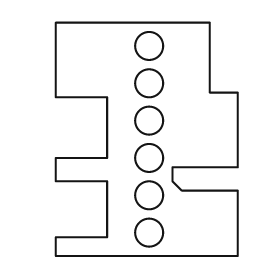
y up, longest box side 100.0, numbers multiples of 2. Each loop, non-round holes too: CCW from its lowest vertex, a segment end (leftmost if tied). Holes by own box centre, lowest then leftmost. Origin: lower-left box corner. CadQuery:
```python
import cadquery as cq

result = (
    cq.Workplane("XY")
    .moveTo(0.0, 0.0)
    .lineTo(78.0, 0.0)
    .lineTo(78.0, 28.0)
    .lineTo(54.0, 28.0)
    .lineTo(50.0, 32.0)
    .lineTo(50.0, 38.0)
    .lineTo(78.0, 38.0)
    .lineTo(78.0, 70.0)
    .lineTo(66.0, 70.0)
    .lineTo(66.0, 100.0)
    .lineTo(0.0, 100.0)
    .lineTo(0.0, 68.0)
    .lineTo(22.0, 68.0)
    .lineTo(22.0, 42.0)
    .lineTo(0.0, 42.0)
    .lineTo(0.0, 32.0)
    .lineTo(22.0, 32.0)
    .lineTo(22.0, 8.0)
    .lineTo(0.0, 8.0)
    .close()
    .moveTo(40.0, 10.0)
    .circle(6.0)
    .moveTo(40.0, 26.0)
    .circle(6.0)
    .moveTo(40.0, 42.0)
    .circle(6.0)
    .moveTo(40.0, 58.0)
    .circle(6.0)
    .moveTo(40.0, 74.0)
    .circle(6.0)
    .moveTo(40.0, 90.0)
    .circle(6.0)
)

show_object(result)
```